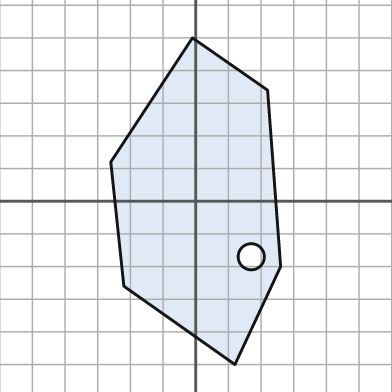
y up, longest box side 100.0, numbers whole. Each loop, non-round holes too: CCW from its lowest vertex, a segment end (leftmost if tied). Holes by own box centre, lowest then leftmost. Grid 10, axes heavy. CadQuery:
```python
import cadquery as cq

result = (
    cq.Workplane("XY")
    .moveTo(12.0, -50.0)
    .lineTo(26.0, -20.0)
    .lineTo(22.0, 34.0)
    .lineTo(-1.0, 50.0)
    .lineTo(-26.0, 12.0)
    .lineTo(-22.0, -26.0)
    .close()
    .moveTo(17.0, -17.0)
    .circle(4.0)
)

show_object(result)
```